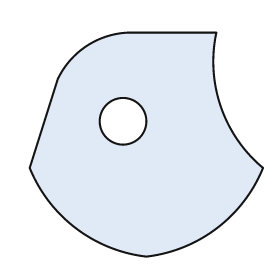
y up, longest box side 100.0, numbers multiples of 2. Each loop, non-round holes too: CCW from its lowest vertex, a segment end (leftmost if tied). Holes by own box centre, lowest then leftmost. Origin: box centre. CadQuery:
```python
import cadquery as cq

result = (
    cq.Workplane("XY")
    .moveTo(0.0, -48.0)
    .threePointArc((30.0, -36.0), (50.0, -10.0))
    .threePointArc((32.0, 16.0), (30.0, 48.0))
    .lineTo(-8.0, 48.0)
    .threePointArc((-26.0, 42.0), (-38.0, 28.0))
    .lineTo(-50.0, -10.0)
    .threePointArc((-30.0, -36.0), (0.0, -48.0))
    .close()
    .moveTo(-10.0, 10.0)
    .circle(10.0)
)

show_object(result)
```